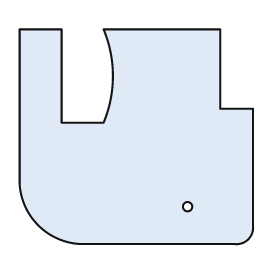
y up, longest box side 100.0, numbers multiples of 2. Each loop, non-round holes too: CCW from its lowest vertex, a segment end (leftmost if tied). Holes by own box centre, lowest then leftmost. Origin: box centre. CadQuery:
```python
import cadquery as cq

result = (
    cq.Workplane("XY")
    .moveTo(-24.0, -46.0)
    .lineTo(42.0, -46.0)
    .threePointArc((48.0, -44.0), (50.0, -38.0))
    .lineTo(50.0, 12.0)
    .lineTo(36.0, 12.0)
    .lineTo(36.0, 46.0)
    .lineTo(-14.0, 46.0)
    .threePointArc((-10.0, 26.0), (-14.0, 6.0))
    .lineTo(-32.0, 6.0)
    .lineTo(-32.0, 46.0)
    .lineTo(-50.0, 46.0)
    .lineTo(-50.0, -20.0)
    .threePointArc((-42.0, -38.0), (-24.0, -46.0))
    .close()
    .moveTo(22.0, -30.0)
    .circle(2.0)
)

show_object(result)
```